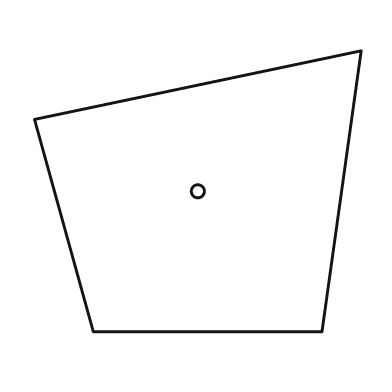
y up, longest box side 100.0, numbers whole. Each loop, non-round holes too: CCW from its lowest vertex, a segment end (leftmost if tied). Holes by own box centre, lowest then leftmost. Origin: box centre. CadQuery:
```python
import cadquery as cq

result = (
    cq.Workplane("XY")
    .moveTo(-32.0, -43.0)
    .lineTo(38.0, -43.0)
    .lineTo(50.0, 43.0)
    .lineTo(-50.0, 22.0)
    .close()
    .moveTo(0.0, 0.0)
    .circle(2.0)
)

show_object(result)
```